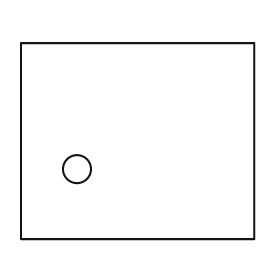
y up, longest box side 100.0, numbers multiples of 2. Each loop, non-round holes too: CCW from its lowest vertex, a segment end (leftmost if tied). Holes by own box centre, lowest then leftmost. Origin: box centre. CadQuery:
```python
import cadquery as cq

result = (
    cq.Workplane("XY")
    .moveTo(-50.0, -42.0)
    .lineTo(50.0, -42.0)
    .lineTo(50.0, 42.0)
    .lineTo(-50.0, 42.0)
    .close()
    .moveTo(-26.0, -12.0)
    .circle(6.0)
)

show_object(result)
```